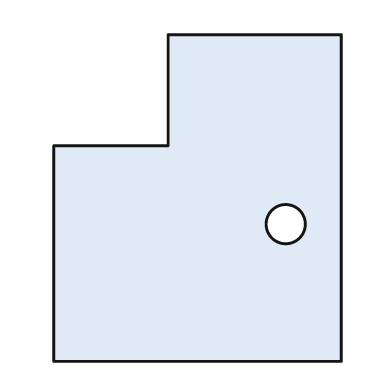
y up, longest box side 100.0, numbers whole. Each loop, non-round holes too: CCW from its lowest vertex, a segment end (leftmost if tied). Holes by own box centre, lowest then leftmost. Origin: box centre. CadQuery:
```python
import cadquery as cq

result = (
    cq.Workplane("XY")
    .moveTo(-44.0, -50.0)
    .lineTo(44.0, -50.0)
    .lineTo(44.0, 50.0)
    .lineTo(-9.0, 50.0)
    .lineTo(-9.0, 16.0)
    .lineTo(-44.0, 16.0)
    .close()
    .moveTo(27.0, -8.0)
    .circle(6.0)
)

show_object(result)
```